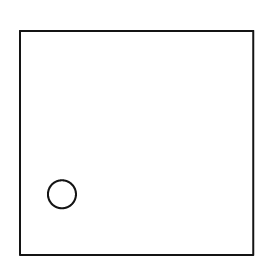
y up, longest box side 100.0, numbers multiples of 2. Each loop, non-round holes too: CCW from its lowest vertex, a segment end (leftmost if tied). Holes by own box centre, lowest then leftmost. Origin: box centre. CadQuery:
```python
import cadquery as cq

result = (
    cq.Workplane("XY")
    .moveTo(-50.0, -48.0)
    .lineTo(50.0, -48.0)
    .lineTo(50.0, 48.0)
    .lineTo(-50.0, 48.0)
    .close()
    .moveTo(-32.0, -22.0)
    .circle(6.0)
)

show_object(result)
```